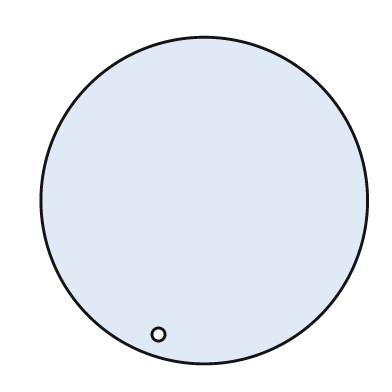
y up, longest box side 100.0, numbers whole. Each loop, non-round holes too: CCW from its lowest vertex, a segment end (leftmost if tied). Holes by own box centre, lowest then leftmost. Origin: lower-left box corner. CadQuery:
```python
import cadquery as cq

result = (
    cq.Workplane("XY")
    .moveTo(50.0, 50.0)
    .circle(50.0)
    .moveTo(36.0, 9.0)
    .circle(2.0)
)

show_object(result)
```